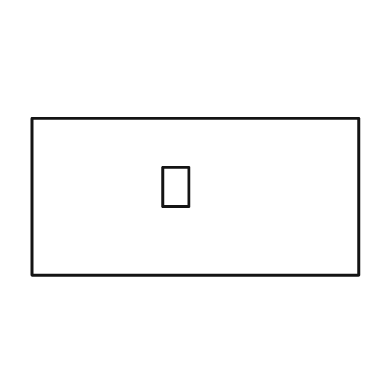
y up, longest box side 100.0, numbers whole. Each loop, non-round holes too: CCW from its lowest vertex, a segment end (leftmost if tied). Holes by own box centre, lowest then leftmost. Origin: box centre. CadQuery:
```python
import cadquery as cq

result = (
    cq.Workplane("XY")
    .moveTo(-50.0, -24.0)
    .lineTo(50.0, -24.0)
    .lineTo(50.0, 24.0)
    .lineTo(-50.0, 24.0)
    .close()
    .moveTo(-10.0, -3.0)
    .lineTo(-2.0, -3.0)
    .lineTo(-2.0, 9.0)
    .lineTo(-10.0, 9.0)
    .close()
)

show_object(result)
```